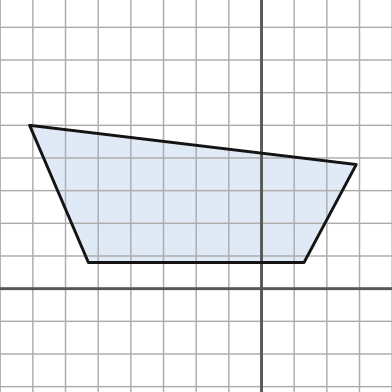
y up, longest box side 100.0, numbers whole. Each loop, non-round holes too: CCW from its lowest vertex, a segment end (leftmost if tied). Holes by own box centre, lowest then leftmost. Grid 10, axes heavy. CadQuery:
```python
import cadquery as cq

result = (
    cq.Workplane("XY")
    .moveTo(-53.0, 8.0)
    .lineTo(13.0, 8.0)
    .lineTo(29.0, 38.0)
    .lineTo(-71.0, 50.0)
    .close()
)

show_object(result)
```